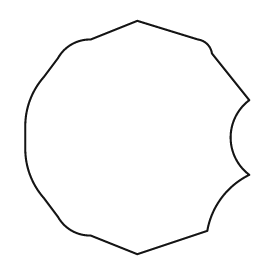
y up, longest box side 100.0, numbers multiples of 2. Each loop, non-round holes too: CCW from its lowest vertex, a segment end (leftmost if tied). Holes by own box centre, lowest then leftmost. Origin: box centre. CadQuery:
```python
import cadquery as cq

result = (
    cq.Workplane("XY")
    .moveTo(0.0, -50.0)
    .lineTo(30.0, -40.0)
    .threePointArc((36.0, -26.0), (48.0, -16.0))
    .threePointArc((40.0, 0.0), (48.0, 16.0))
    .lineTo(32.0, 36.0)
    .threePointArc((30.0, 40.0), (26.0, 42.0))
    .lineTo(0.0, 50.0)
    .lineTo(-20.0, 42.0)
    .threePointArc((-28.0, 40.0), (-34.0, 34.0))
    .lineTo(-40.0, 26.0)
    .threePointArc((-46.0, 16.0), (-48.0, 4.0))
    .lineTo(-48.0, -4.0)
    .threePointArc((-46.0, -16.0), (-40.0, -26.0))
    .lineTo(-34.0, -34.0)
    .threePointArc((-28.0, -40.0), (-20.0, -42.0))
    .close()
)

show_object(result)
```